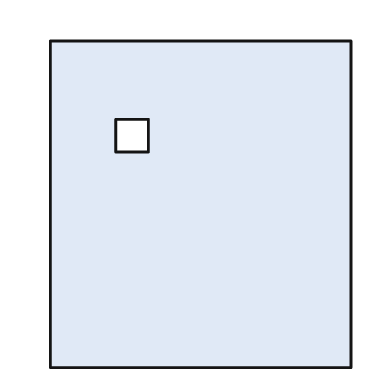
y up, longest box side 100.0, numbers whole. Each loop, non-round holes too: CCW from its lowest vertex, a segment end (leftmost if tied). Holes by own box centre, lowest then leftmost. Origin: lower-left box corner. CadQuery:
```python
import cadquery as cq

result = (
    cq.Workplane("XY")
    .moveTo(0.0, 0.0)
    .lineTo(92.0, 0.0)
    .lineTo(92.0, 100.0)
    .lineTo(0.0, 100.0)
    .close()
    .moveTo(20.0, 66.0)
    .lineTo(30.0, 66.0)
    .lineTo(30.0, 76.0)
    .lineTo(20.0, 76.0)
    .close()
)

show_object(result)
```